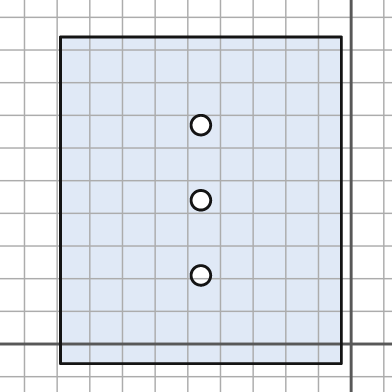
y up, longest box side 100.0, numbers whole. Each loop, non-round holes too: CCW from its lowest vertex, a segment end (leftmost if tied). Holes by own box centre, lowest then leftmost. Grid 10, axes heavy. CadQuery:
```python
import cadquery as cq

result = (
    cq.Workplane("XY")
    .moveTo(-89.0, -6.0)
    .lineTo(-3.0, -6.0)
    .lineTo(-3.0, 94.0)
    .lineTo(-89.0, 94.0)
    .close()
    .moveTo(-46.0, 21.0)
    .circle(3.0)
    .moveTo(-46.0, 44.0)
    .circle(3.0)
    .moveTo(-46.0, 67.0)
    .circle(3.0)
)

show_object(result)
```